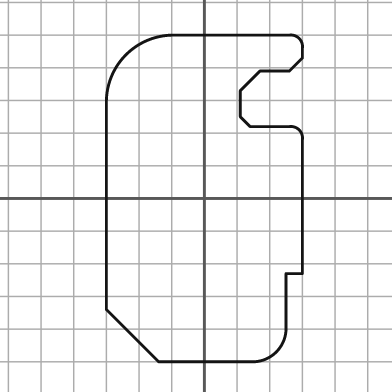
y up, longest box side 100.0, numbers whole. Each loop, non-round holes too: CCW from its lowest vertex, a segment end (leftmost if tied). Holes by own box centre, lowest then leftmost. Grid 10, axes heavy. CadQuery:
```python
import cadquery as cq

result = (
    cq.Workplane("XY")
    .moveTo(-14.0, -50.0)
    .lineTo(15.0, -50.0)
    .threePointArc((22.0, -47.0), (25.0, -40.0))
    .lineTo(25.0, -23.0)
    .lineTo(30.0, -23.0)
    .lineTo(30.0, 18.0)
    .threePointArc((29.0, 21.0), (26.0, 22.0))
    .lineTo(14.0, 22.0)
    .lineTo(11.0, 25.0)
    .lineTo(11.0, 33.0)
    .lineTo(17.0, 39.0)
    .lineTo(26.0, 39.0)
    .lineTo(30.0, 43.0)
    .lineTo(30.0, 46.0)
    .threePointArc((29.0, 49.0), (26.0, 50.0))
    .lineTo(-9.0, 50.0)
    .threePointArc((-24.0, 44.0), (-30.0, 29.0))
    .lineTo(-30.0, -34.0)
    .close()
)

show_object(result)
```